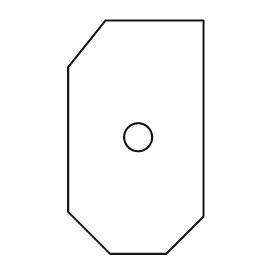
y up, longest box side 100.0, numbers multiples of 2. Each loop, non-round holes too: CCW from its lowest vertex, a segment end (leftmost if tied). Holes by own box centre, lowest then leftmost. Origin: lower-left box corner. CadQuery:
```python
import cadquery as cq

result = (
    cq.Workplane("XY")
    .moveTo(18.0, 0.0)
    .lineTo(42.0, 0.0)
    .lineTo(58.0, 16.0)
    .lineTo(58.0, 100.0)
    .lineTo(16.0, 100.0)
    .lineTo(0.0, 80.0)
    .lineTo(0.0, 18.0)
    .close()
    .moveTo(30.0, 50.0)
    .circle(6.0)
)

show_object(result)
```